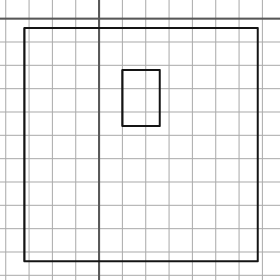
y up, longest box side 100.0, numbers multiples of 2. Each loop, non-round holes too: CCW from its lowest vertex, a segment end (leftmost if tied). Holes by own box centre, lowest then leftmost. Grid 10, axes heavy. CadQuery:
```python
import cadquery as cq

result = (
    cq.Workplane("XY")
    .moveTo(-32.0, -104.0)
    .lineTo(68.0, -104.0)
    .lineTo(68.0, -4.0)
    .lineTo(-32.0, -4.0)
    .close()
    .moveTo(10.0, -46.0)
    .lineTo(26.0, -46.0)
    .lineTo(26.0, -22.0)
    .lineTo(10.0, -22.0)
    .close()
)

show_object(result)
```